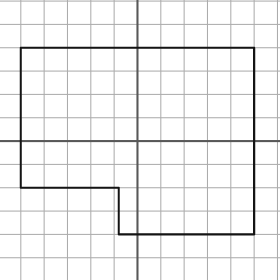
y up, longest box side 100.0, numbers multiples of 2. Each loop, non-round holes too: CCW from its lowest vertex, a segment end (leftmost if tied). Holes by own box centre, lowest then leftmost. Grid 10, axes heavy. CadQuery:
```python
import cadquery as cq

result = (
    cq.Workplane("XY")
    .moveTo(-8.0, -40.0)
    .lineTo(50.0, -40.0)
    .lineTo(50.0, 40.0)
    .lineTo(-50.0, 40.0)
    .lineTo(-50.0, -20.0)
    .lineTo(-8.0, -20.0)
    .close()
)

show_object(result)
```